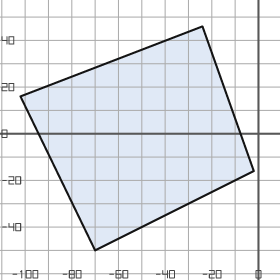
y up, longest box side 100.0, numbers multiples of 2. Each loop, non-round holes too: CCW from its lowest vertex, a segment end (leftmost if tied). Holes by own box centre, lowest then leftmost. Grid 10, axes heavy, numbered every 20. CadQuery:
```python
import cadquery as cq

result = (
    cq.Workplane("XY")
    .moveTo(-70.0, -50.0)
    .lineTo(-2.0, -16.0)
    .lineTo(-24.0, 46.0)
    .lineTo(-102.0, 16.0)
    .close()
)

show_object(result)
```